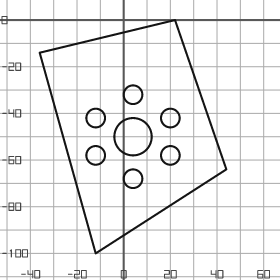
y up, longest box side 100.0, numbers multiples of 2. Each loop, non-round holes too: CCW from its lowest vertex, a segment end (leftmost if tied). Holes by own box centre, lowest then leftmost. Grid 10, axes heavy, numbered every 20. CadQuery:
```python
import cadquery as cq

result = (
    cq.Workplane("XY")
    .moveTo(-12.0, -100.0)
    .lineTo(44.0, -64.0)
    .lineTo(22.0, 0.0)
    .lineTo(-36.0, -14.0)
    .close()
    .moveTo(4.0, -68.0)
    .circle(4.0)
    .moveTo(-12.0, -58.0)
    .circle(4.0)
    .moveTo(20.0, -58.0)
    .circle(4.0)
    .moveTo(4.0, -50.0)
    .circle(8.0)
    .moveTo(-12.0, -42.0)
    .circle(4.0)
    .moveTo(20.0, -42.0)
    .circle(4.0)
    .moveTo(4.0, -32.0)
    .circle(4.0)
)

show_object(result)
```